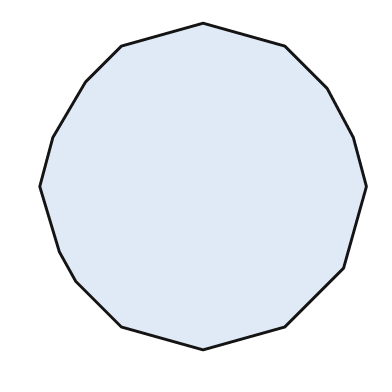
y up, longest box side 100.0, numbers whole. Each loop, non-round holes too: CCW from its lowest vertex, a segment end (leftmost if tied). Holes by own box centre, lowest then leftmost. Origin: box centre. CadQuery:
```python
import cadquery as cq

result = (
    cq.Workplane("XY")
    .moveTo(0.0, -50.0)
    .lineTo(25.0, -43.0)
    .lineTo(43.0, -25.0)
    .lineTo(50.0, 0.0)
    .lineTo(46.0, 15.0)
    .lineTo(38.0, 30.0)
    .lineTo(25.0, 43.0)
    .lineTo(0.0, 50.0)
    .lineTo(-25.0, 43.0)
    .lineTo(-36.0, 32.0)
    .lineTo(-46.0, 15.0)
    .lineTo(-50.0, 0.0)
    .lineTo(-44.0, -20.0)
    .lineTo(-39.0, -29.0)
    .lineTo(-25.0, -43.0)
    .close()
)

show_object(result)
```